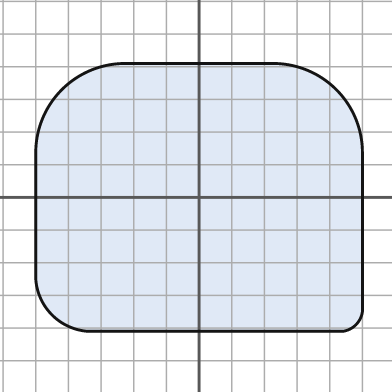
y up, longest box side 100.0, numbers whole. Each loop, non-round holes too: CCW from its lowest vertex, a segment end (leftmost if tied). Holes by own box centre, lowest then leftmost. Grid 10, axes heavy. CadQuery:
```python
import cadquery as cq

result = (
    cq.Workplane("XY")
    .moveTo(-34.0, -41.0)
    .lineTo(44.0, -41.0)
    .threePointArc((48.0, -39.0), (50.0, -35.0))
    .lineTo(50.0, 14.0)
    .threePointArc((42.0, 33.0), (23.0, 41.0))
    .lineTo(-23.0, 41.0)
    .threePointArc((-42.0, 33.0), (-50.0, 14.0))
    .lineTo(-50.0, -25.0)
    .threePointArc((-45.0, -36.0), (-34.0, -41.0))
    .close()
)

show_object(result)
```